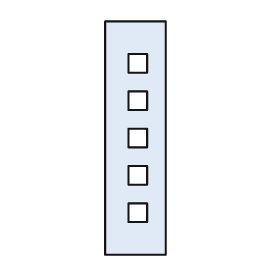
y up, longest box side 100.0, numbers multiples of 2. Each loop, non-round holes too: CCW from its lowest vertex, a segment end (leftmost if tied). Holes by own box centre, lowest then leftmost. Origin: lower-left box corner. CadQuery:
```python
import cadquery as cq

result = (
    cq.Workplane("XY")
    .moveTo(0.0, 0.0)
    .lineTo(26.0, 0.0)
    .lineTo(26.0, 100.0)
    .lineTo(0.0, 100.0)
    .close()
    .moveTo(10.0, 14.0)
    .lineTo(18.0, 14.0)
    .lineTo(18.0, 22.0)
    .lineTo(10.0, 22.0)
    .close()
    .moveTo(10.0, 30.0)
    .lineTo(18.0, 30.0)
    .lineTo(18.0, 38.0)
    .lineTo(10.0, 38.0)
    .close()
    .moveTo(10.0, 46.0)
    .lineTo(18.0, 46.0)
    .lineTo(18.0, 54.0)
    .lineTo(10.0, 54.0)
    .close()
    .moveTo(10.0, 62.0)
    .lineTo(18.0, 62.0)
    .lineTo(18.0, 70.0)
    .lineTo(10.0, 70.0)
    .close()
    .moveTo(10.0, 78.0)
    .lineTo(18.0, 78.0)
    .lineTo(18.0, 86.0)
    .lineTo(10.0, 86.0)
    .close()
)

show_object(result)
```